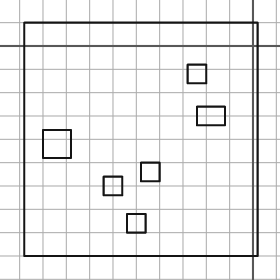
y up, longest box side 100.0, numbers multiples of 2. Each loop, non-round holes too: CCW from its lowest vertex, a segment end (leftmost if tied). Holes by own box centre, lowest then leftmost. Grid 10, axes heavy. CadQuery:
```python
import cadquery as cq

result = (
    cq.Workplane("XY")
    .moveTo(-98.0, -90.0)
    .lineTo(2.0, -90.0)
    .lineTo(2.0, 10.0)
    .lineTo(-98.0, 10.0)
    .close()
    .moveTo(-54.0, -80.0)
    .lineTo(-46.0, -80.0)
    .lineTo(-46.0, -72.0)
    .lineTo(-54.0, -72.0)
    .close()
    .moveTo(-64.0, -64.0)
    .lineTo(-56.0, -64.0)
    .lineTo(-56.0, -56.0)
    .lineTo(-64.0, -56.0)
    .close()
    .moveTo(-48.0, -58.0)
    .lineTo(-40.0, -58.0)
    .lineTo(-40.0, -50.0)
    .lineTo(-48.0, -50.0)
    .close()
    .moveTo(-90.0, -48.0)
    .lineTo(-78.0, -48.0)
    .lineTo(-78.0, -36.0)
    .lineTo(-90.0, -36.0)
    .close()
    .moveTo(-24.0, -34.0)
    .lineTo(-12.0, -34.0)
    .lineTo(-12.0, -26.0)
    .lineTo(-24.0, -26.0)
    .close()
    .moveTo(-28.0, -16.0)
    .lineTo(-20.0, -16.0)
    .lineTo(-20.0, -8.0)
    .lineTo(-28.0, -8.0)
    .close()
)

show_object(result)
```